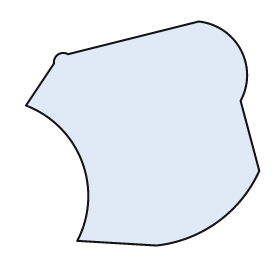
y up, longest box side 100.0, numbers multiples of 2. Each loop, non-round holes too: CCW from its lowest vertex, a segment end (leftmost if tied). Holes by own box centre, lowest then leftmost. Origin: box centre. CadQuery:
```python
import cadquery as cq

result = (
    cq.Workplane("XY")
    .moveTo(6.0, -48.0)
    .threePointArc((32.0, -38.0), (50.0, -16.0))
    .lineTo(42.0, 14.0)
    .threePointArc((42.0, 36.0), (24.0, 48.0))
    .lineTo(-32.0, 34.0)
    .threePointArc((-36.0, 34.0), (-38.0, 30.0))
    .lineTo(-50.0, 12.0)
    .threePointArc((-26.0, -12.0), (-28.0, -46.0))
    .close()
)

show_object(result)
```